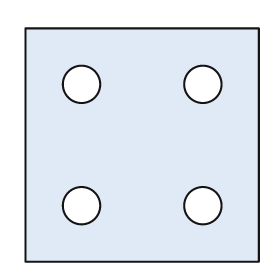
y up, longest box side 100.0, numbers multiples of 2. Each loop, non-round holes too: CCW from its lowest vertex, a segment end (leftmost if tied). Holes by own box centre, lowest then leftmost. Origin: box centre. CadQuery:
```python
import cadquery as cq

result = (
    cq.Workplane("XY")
    .moveTo(-50.0, -50.0)
    .lineTo(50.0, -50.0)
    .lineTo(50.0, 50.0)
    .lineTo(-50.0, 50.0)
    .close()
    .moveTo(-26.0, -26.0)
    .circle(8.0)
    .moveTo(26.0, -26.0)
    .circle(8.0)
    .moveTo(-26.0, 26.0)
    .circle(8.0)
    .moveTo(26.0, 26.0)
    .circle(8.0)
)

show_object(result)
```